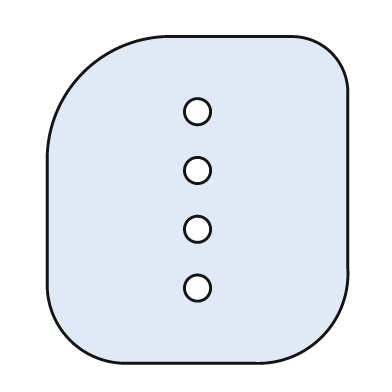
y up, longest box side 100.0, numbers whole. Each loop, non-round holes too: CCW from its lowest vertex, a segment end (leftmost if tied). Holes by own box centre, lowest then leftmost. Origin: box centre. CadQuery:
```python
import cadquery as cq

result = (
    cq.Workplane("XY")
    .moveTo(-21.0, -50.0)
    .lineTo(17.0, -50.0)
    .threePointArc((38.0, -42.0), (46.0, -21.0))
    .lineTo(46.0, 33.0)
    .threePointArc((41.0, 45.0), (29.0, 50.0))
    .lineTo(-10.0, 50.0)
    .threePointArc((-35.0, 39.0), (-46.0, 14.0))
    .lineTo(-46.0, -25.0)
    .threePointArc((-39.0, -43.0), (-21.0, -50.0))
    .close()
    .moveTo(0.0, -27.0)
    .circle(4.0)
    .moveTo(0.0, -9.0)
    .circle(4.0)
    .moveTo(0.0, 9.0)
    .circle(4.0)
    .moveTo(0.0, 27.0)
    .circle(4.0)
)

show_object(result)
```